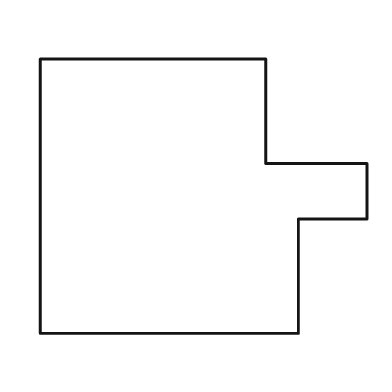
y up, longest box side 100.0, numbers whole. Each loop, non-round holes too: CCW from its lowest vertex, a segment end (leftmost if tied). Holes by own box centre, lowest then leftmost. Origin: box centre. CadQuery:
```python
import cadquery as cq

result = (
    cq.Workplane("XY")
    .moveTo(-50.0, -42.0)
    .lineTo(29.0, -42.0)
    .lineTo(29.0, -7.0)
    .lineTo(50.0, -7.0)
    .lineTo(50.0, 10.0)
    .lineTo(19.0, 10.0)
    .lineTo(19.0, 42.0)
    .lineTo(-50.0, 42.0)
    .close()
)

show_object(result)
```